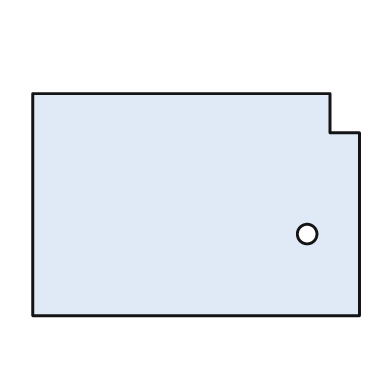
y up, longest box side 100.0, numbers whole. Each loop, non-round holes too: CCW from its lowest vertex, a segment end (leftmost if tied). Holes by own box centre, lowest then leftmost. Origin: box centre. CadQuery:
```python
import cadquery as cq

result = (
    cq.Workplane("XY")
    .moveTo(-50.0, -34.0)
    .lineTo(50.0, -34.0)
    .lineTo(50.0, 22.0)
    .lineTo(41.0, 22.0)
    .lineTo(41.0, 34.0)
    .lineTo(-50.0, 34.0)
    .close()
    .moveTo(34.0, -9.0)
    .circle(3.0)
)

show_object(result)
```